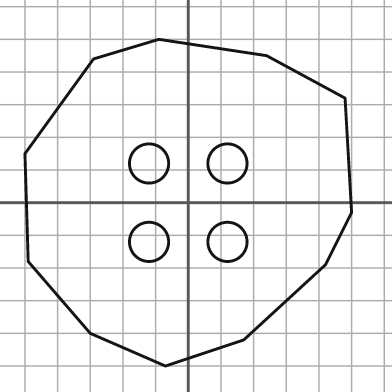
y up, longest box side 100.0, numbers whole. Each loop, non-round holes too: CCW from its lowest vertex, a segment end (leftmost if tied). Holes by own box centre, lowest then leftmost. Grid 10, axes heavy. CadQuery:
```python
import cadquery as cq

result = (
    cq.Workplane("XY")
    .moveTo(-7.0, -50.0)
    .lineTo(17.0, -42.0)
    .lineTo(42.0, -19.0)
    .lineTo(50.0, -3.0)
    .lineTo(48.0, 32.0)
    .lineTo(24.0, 45.0)
    .lineTo(-9.0, 50.0)
    .lineTo(-29.0, 44.0)
    .lineTo(-50.0, 15.0)
    .lineTo(-49.0, -18.0)
    .lineTo(-30.0, -40.0)
    .close()
    .moveTo(-12.0, -12.0)
    .circle(6.0)
    .moveTo(12.0, -12.0)
    .circle(6.0)
    .moveTo(-12.0, 12.0)
    .circle(6.0)
    .moveTo(12.0, 12.0)
    .circle(6.0)
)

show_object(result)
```